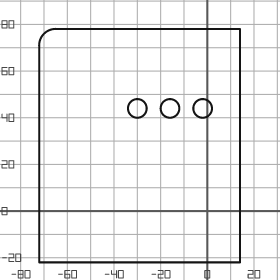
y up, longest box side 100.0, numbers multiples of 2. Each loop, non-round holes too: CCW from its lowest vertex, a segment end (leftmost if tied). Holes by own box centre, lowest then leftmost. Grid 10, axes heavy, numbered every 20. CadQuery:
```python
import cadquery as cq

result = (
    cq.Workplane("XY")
    .moveTo(-72.0, -22.0)
    .lineTo(14.0, -22.0)
    .lineTo(14.0, 78.0)
    .lineTo(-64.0, 78.0)
    .threePointArc((-70.0, 76.0), (-72.0, 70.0))
    .close()
    .moveTo(-30.0, 44.0)
    .circle(4.0)
    .moveTo(-16.0, 44.0)
    .circle(4.0)
    .moveTo(-2.0, 44.0)
    .circle(4.0)
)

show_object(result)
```